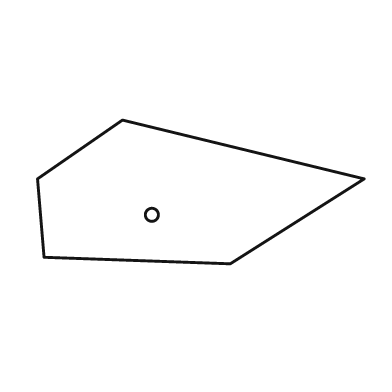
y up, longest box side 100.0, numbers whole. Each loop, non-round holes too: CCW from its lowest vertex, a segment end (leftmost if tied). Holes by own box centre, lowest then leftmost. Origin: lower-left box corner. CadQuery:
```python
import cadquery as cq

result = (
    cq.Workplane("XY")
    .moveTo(59.0, 0.0)
    .lineTo(100.0, 26.0)
    .lineTo(26.0, 44.0)
    .lineTo(0.0, 26.0)
    .lineTo(2.0, 2.0)
    .close()
    .moveTo(35.0, 15.0)
    .circle(2.0)
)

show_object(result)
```